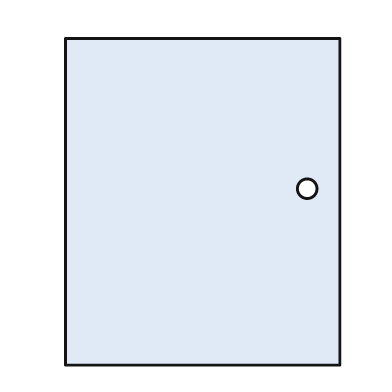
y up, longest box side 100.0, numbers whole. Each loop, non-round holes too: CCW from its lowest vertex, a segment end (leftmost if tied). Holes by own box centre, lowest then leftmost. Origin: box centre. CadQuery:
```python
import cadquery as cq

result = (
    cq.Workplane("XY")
    .moveTo(-42.0, -50.0)
    .lineTo(42.0, -50.0)
    .lineTo(42.0, 50.0)
    .lineTo(-42.0, 50.0)
    .close()
    .moveTo(32.0, 4.0)
    .circle(3.0)
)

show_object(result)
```